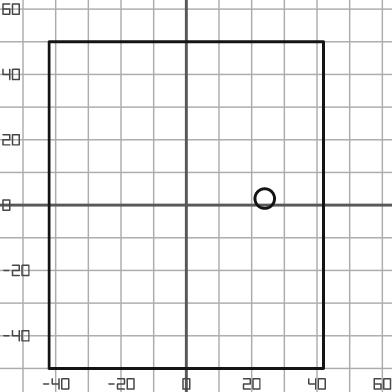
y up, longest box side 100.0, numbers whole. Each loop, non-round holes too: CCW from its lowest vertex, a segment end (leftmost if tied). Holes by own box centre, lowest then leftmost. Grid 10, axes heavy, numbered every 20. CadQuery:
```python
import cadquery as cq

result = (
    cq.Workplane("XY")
    .moveTo(-42.0, -50.0)
    .lineTo(42.0, -50.0)
    .lineTo(42.0, 50.0)
    .lineTo(-42.0, 50.0)
    .close()
    .moveTo(24.0, 2.0)
    .circle(3.0)
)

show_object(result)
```